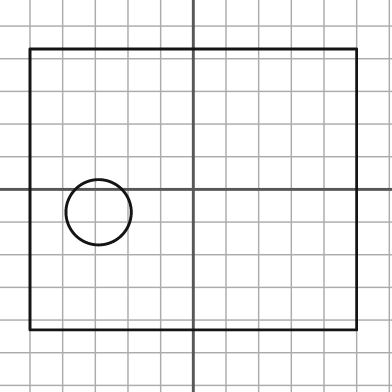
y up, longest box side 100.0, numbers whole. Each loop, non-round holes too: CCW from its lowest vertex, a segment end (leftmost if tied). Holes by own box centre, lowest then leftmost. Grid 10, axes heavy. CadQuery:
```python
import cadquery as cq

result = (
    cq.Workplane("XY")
    .moveTo(-50.0, -43.0)
    .lineTo(50.0, -43.0)
    .lineTo(50.0, 43.0)
    .lineTo(-50.0, 43.0)
    .close()
    .moveTo(-29.0, -7.0)
    .circle(10.0)
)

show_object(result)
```